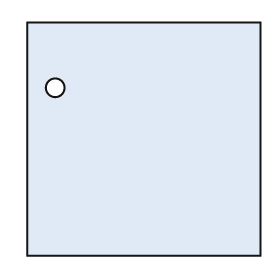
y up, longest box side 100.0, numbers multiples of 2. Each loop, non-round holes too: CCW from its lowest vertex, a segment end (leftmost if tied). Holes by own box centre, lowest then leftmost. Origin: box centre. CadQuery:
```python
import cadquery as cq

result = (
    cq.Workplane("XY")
    .moveTo(-50.0, -50.0)
    .lineTo(50.0, -50.0)
    .lineTo(50.0, 50.0)
    .lineTo(-50.0, 50.0)
    .close()
    .moveTo(-38.0, 22.0)
    .circle(4.0)
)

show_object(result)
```